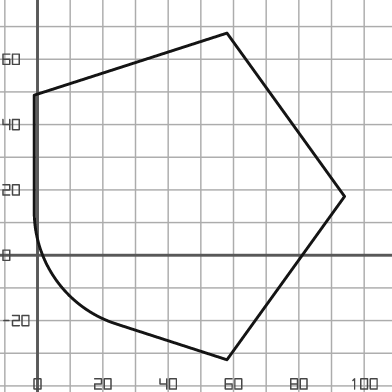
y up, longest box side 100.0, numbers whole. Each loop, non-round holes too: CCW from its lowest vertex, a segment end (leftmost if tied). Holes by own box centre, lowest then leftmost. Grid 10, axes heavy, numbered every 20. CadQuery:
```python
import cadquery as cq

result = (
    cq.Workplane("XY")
    .moveTo(58.0, -32.0)
    .lineTo(94.0, 18.0)
    .lineTo(58.0, 68.0)
    .lineTo(-1.0, 49.0)
    .lineTo(-1.0, 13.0)
    .threePointArc((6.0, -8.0), (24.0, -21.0))
    .close()
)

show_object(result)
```